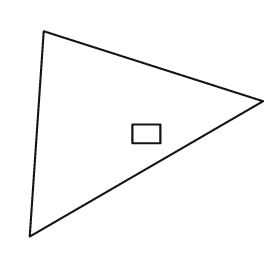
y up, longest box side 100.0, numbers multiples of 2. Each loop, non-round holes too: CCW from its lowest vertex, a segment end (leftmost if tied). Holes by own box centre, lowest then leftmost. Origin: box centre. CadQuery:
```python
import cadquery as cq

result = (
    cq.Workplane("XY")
    .moveTo(-50.0, -44.0)
    .lineTo(50.0, 14.0)
    .lineTo(-44.0, 44.0)
    .close()
    .moveTo(-6.0, -4.0)
    .lineTo(6.0, -4.0)
    .lineTo(6.0, 4.0)
    .lineTo(-6.0, 4.0)
    .close()
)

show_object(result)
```